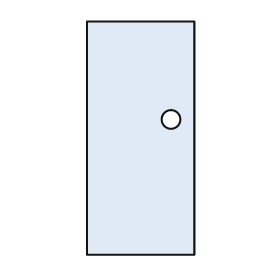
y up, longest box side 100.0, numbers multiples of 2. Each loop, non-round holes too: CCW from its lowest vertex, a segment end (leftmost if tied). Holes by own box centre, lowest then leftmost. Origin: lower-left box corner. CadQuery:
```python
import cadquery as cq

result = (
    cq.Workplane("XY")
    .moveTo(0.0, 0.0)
    .lineTo(46.0, 0.0)
    .lineTo(46.0, 100.0)
    .lineTo(0.0, 100.0)
    .close()
    .moveTo(36.0, 58.0)
    .circle(4.0)
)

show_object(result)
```